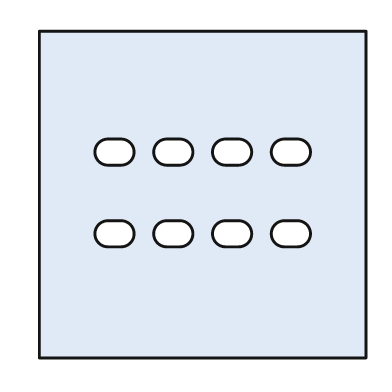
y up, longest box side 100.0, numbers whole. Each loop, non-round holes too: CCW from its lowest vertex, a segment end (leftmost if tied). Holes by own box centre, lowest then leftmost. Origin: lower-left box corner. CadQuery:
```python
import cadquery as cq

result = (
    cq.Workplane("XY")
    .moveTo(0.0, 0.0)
    .lineTo(100.0, 0.0)
    .lineTo(100.0, 100.0)
    .lineTo(0.0, 100.0)
    .close()
    .moveTo(21.0, 34.0)
    .lineTo(25.0, 34.0)
    .threePointArc((29.0, 38.0), (25.0, 42.0))
    .lineTo(21.0, 42.0)
    .threePointArc((17.0, 38.0), (21.0, 34.0))
    .close()
    .moveTo(39.0, 34.0)
    .lineTo(43.0, 34.0)
    .threePointArc((47.0, 38.0), (43.0, 42.0))
    .lineTo(39.0, 42.0)
    .threePointArc((35.0, 38.0), (39.0, 34.0))
    .close()
    .moveTo(57.0, 34.0)
    .lineTo(61.0, 34.0)
    .threePointArc((65.0, 38.0), (61.0, 42.0))
    .lineTo(57.0, 42.0)
    .threePointArc((53.0, 38.0), (57.0, 34.0))
    .close()
    .moveTo(75.0, 34.0)
    .lineTo(79.0, 34.0)
    .threePointArc((83.0, 38.0), (79.0, 42.0))
    .lineTo(75.0, 42.0)
    .threePointArc((71.0, 38.0), (75.0, 34.0))
    .close()
    .moveTo(21.0, 59.0)
    .lineTo(25.0, 59.0)
    .threePointArc((29.0, 63.0), (25.0, 67.0))
    .lineTo(21.0, 67.0)
    .threePointArc((17.0, 63.0), (21.0, 59.0))
    .close()
    .moveTo(39.0, 59.0)
    .lineTo(43.0, 59.0)
    .threePointArc((47.0, 63.0), (43.0, 67.0))
    .lineTo(39.0, 67.0)
    .threePointArc((35.0, 63.0), (39.0, 59.0))
    .close()
    .moveTo(57.0, 59.0)
    .lineTo(61.0, 59.0)
    .threePointArc((65.0, 63.0), (61.0, 67.0))
    .lineTo(57.0, 67.0)
    .threePointArc((53.0, 63.0), (57.0, 59.0))
    .close()
    .moveTo(75.0, 59.0)
    .lineTo(79.0, 59.0)
    .threePointArc((83.0, 63.0), (79.0, 67.0))
    .lineTo(75.0, 67.0)
    .threePointArc((71.0, 63.0), (75.0, 59.0))
    .close()
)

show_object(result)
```